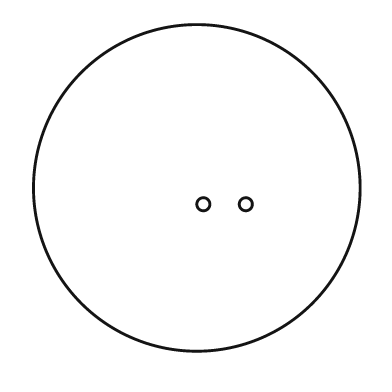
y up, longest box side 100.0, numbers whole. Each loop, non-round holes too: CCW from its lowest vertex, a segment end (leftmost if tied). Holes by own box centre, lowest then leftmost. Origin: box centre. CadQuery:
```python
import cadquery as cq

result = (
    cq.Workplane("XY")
    .moveTo(0.0, 0.0)
    .circle(50.0)
    .moveTo(2.0, -5.0)
    .circle(2.0)
    .moveTo(15.0, -5.0)
    .circle(2.0)
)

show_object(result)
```